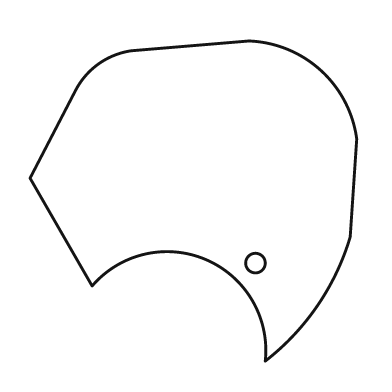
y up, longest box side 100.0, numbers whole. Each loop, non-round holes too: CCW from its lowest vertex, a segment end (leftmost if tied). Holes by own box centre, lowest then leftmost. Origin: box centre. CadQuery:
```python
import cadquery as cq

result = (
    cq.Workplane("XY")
    .moveTo(22.0, -49.0)
    .threePointArc((38.0, -32.0), (48.0, -11.0))
    .lineTo(50.0, 19.0)
    .threePointArc((39.0, 40.0), (17.0, 49.0))
    .lineTo(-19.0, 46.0)
    .threePointArc((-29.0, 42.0), (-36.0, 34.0))
    .lineTo(-50.0, 7.0)
    .lineTo(-31.0, -26.0)
    .threePointArc((4.0, -18.0), (22.0, -49.0))
    .close()
    .moveTo(19.0, -19.0)
    .circle(3.0)
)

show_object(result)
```